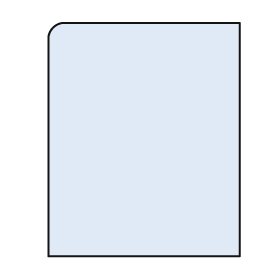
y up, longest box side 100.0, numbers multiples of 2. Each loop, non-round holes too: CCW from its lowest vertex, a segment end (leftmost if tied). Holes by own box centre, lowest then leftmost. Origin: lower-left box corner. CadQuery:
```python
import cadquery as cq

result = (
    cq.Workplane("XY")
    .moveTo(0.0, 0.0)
    .lineTo(82.0, 0.0)
    .lineTo(82.0, 100.0)
    .lineTo(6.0, 100.0)
    .threePointArc((2.0, 98.0), (0.0, 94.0))
    .close()
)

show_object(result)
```